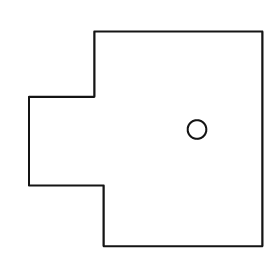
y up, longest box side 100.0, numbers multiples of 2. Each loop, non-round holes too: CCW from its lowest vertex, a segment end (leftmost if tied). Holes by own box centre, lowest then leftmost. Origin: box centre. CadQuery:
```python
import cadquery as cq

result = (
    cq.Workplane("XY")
    .moveTo(-18.0, -46.0)
    .lineTo(50.0, -46.0)
    .lineTo(50.0, 46.0)
    .lineTo(-22.0, 46.0)
    .lineTo(-22.0, 18.0)
    .lineTo(-50.0, 18.0)
    .lineTo(-50.0, -20.0)
    .lineTo(-18.0, -20.0)
    .close()
    .moveTo(22.0, 4.0)
    .circle(4.0)
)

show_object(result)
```